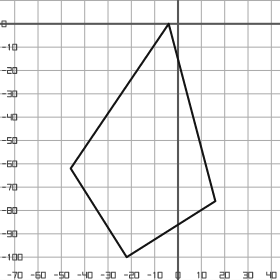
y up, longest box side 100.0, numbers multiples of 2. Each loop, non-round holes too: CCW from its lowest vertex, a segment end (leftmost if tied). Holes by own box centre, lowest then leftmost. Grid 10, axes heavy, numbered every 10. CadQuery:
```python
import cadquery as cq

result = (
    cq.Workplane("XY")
    .moveTo(-22.0, -100.0)
    .lineTo(16.0, -76.0)
    .lineTo(-4.0, 0.0)
    .lineTo(-46.0, -62.0)
    .close()
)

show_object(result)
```